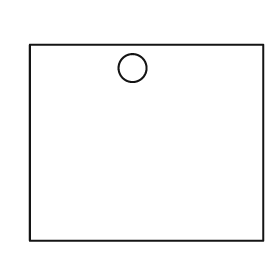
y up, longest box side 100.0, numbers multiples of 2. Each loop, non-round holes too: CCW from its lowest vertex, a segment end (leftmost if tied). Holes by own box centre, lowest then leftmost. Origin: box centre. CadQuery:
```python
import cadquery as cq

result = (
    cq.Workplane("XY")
    .moveTo(-50.0, -42.0)
    .lineTo(50.0, -42.0)
    .lineTo(50.0, 42.0)
    .lineTo(-50.0, 42.0)
    .close()
    .moveTo(-6.0, 32.0)
    .circle(6.0)
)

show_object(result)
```